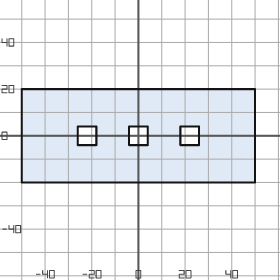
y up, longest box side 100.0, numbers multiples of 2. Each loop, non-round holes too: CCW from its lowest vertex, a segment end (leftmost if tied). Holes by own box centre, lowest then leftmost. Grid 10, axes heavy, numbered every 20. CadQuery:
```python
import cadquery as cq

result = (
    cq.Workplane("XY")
    .moveTo(-50.0, -20.0)
    .lineTo(50.0, -20.0)
    .lineTo(50.0, 20.0)
    .lineTo(-50.0, 20.0)
    .close()
    .moveTo(-26.0, -4.0)
    .lineTo(-18.0, -4.0)
    .lineTo(-18.0, 4.0)
    .lineTo(-26.0, 4.0)
    .close()
    .moveTo(-4.0, -4.0)
    .lineTo(4.0, -4.0)
    .lineTo(4.0, 4.0)
    .lineTo(-4.0, 4.0)
    .close()
    .moveTo(18.0, -4.0)
    .lineTo(26.0, -4.0)
    .lineTo(26.0, 4.0)
    .lineTo(18.0, 4.0)
    .close()
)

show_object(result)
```